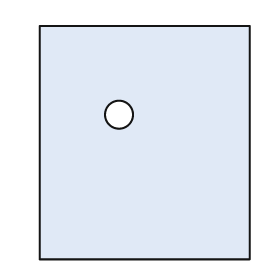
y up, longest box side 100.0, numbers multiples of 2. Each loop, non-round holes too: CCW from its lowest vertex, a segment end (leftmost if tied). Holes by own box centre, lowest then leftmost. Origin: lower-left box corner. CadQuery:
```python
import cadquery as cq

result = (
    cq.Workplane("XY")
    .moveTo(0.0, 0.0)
    .lineTo(90.0, 0.0)
    .lineTo(90.0, 100.0)
    .lineTo(0.0, 100.0)
    .close()
    .moveTo(34.0, 62.0)
    .circle(6.0)
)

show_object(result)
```